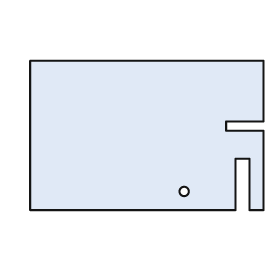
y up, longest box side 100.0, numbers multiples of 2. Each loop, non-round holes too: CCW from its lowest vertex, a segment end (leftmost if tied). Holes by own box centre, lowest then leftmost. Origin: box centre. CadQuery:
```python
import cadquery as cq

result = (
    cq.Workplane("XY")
    .moveTo(-50.0, -32.0)
    .lineTo(38.0, -32.0)
    .lineTo(38.0, -10.0)
    .lineTo(44.0, -10.0)
    .lineTo(44.0, -32.0)
    .lineTo(50.0, -32.0)
    .lineTo(50.0, 2.0)
    .lineTo(34.0, 2.0)
    .lineTo(34.0, 6.0)
    .lineTo(50.0, 6.0)
    .lineTo(50.0, 32.0)
    .lineTo(-50.0, 32.0)
    .close()
    .moveTo(16.0, -24.0)
    .circle(2.0)
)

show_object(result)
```